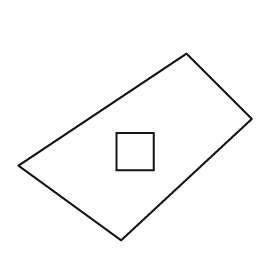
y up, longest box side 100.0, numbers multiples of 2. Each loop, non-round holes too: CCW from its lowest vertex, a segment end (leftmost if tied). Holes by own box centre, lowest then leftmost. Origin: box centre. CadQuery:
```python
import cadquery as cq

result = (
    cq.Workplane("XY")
    .moveTo(-6.0, -40.0)
    .lineTo(50.0, 12.0)
    .lineTo(22.0, 40.0)
    .lineTo(-50.0, -8.0)
    .close()
    .moveTo(-8.0, -10.0)
    .lineTo(8.0, -10.0)
    .lineTo(8.0, 6.0)
    .lineTo(-8.0, 6.0)
    .close()
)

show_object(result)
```